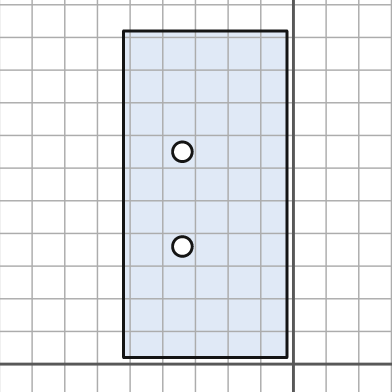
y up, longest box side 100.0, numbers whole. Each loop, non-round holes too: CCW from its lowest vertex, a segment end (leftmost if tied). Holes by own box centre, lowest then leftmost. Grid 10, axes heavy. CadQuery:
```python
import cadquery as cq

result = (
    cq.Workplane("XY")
    .moveTo(-52.0, 2.0)
    .lineTo(-2.0, 2.0)
    .lineTo(-2.0, 102.0)
    .lineTo(-52.0, 102.0)
    .close()
    .moveTo(-34.0, 36.0)
    .circle(3.0)
    .moveTo(-34.0, 65.0)
    .circle(3.0)
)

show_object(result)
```